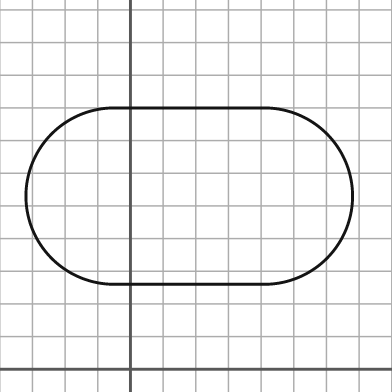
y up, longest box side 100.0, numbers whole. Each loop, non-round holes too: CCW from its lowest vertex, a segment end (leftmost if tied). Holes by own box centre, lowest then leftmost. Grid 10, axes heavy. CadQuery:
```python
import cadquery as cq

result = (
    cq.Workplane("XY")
    .moveTo(-5.0, 26.0)
    .lineTo(41.0, 26.0)
    .threePointArc((68.0, 53.0), (41.0, 80.0))
    .lineTo(-5.0, 80.0)
    .threePointArc((-32.0, 53.0), (-5.0, 26.0))
    .close()
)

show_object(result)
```